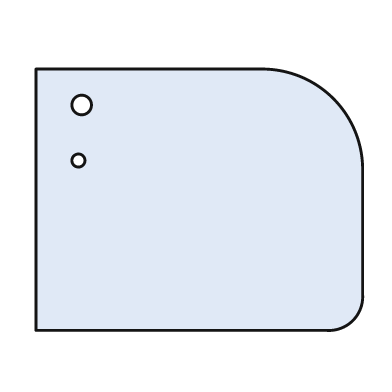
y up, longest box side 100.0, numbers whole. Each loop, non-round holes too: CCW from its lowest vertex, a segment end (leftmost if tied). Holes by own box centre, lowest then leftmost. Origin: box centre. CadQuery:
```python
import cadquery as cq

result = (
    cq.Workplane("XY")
    .moveTo(-50.0, -40.0)
    .lineTo(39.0, -40.0)
    .threePointArc((47.0, -37.0), (50.0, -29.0))
    .lineTo(50.0, 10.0)
    .threePointArc((41.0, 31.0), (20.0, 40.0))
    .lineTo(-50.0, 40.0)
    .close()
    .moveTo(-37.0, 12.0)
    .circle(2.0)
    .moveTo(-36.0, 29.0)
    .circle(3.0)
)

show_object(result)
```